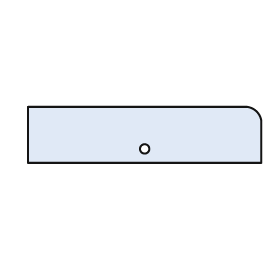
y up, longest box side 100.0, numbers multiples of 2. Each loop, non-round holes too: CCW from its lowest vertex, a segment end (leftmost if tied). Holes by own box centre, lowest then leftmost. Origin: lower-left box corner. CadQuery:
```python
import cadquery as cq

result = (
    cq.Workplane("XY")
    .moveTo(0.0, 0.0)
    .lineTo(100.0, 0.0)
    .lineTo(100.0, 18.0)
    .threePointArc((98.0, 22.0), (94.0, 24.0))
    .lineTo(0.0, 24.0)
    .close()
    .moveTo(50.0, 6.0)
    .circle(2.0)
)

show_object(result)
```